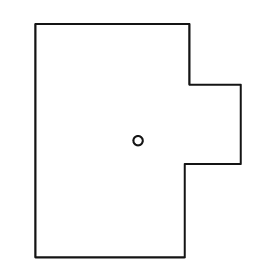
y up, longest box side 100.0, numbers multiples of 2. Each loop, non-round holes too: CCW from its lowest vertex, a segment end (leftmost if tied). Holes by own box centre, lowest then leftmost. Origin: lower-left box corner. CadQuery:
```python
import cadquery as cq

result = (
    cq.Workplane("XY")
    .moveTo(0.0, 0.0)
    .lineTo(64.0, 0.0)
    .lineTo(64.0, 40.0)
    .lineTo(88.0, 40.0)
    .lineTo(88.0, 74.0)
    .lineTo(66.0, 74.0)
    .lineTo(66.0, 100.0)
    .lineTo(0.0, 100.0)
    .close()
    .moveTo(44.0, 50.0)
    .circle(2.0)
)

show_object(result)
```